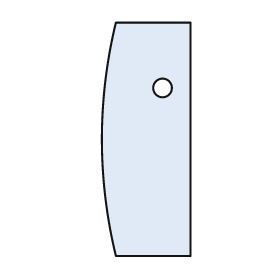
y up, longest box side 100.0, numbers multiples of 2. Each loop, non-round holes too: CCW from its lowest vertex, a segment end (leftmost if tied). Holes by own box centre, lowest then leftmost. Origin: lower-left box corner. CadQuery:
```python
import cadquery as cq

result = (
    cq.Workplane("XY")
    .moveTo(6.0, 0.0)
    .lineTo(38.0, 0.0)
    .lineTo(38.0, 100.0)
    .lineTo(6.0, 100.0)
    .threePointArc((0.0, 50.0), (6.0, 0.0))
    .close()
    .moveTo(26.0, 72.0)
    .circle(4.0)
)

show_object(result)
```